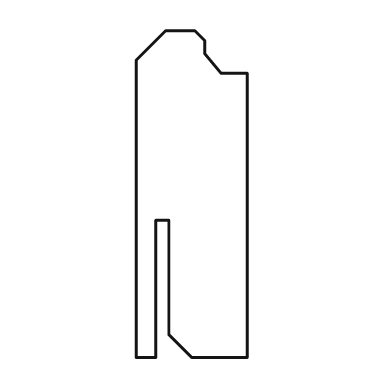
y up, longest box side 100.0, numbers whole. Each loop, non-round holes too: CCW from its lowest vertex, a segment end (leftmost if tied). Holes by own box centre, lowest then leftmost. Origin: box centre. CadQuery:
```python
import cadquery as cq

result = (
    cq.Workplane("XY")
    .moveTo(-17.0, -50.0)
    .lineTo(-11.0, -50.0)
    .lineTo(-11.0, -8.0)
    .lineTo(-7.0, -8.0)
    .lineTo(-7.0, -43.0)
    .lineTo(0.0, -50.0)
    .lineTo(17.0, -50.0)
    .lineTo(17.0, 37.0)
    .lineTo(9.0, 37.0)
    .lineTo(4.0, 43.0)
    .lineTo(4.0, 47.0)
    .lineTo(1.0, 50.0)
    .lineTo(-8.0, 50.0)
    .lineTo(-17.0, 41.0)
    .close()
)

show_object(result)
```